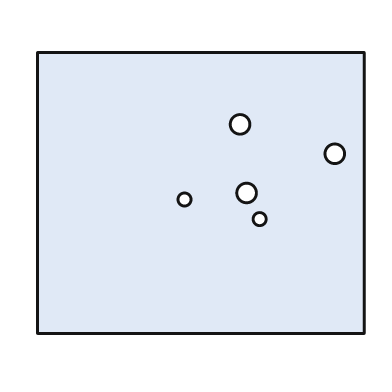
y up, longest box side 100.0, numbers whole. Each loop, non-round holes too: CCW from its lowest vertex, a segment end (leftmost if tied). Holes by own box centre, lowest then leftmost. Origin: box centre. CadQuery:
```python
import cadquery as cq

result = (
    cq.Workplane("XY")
    .moveTo(-50.0, -43.0)
    .lineTo(50.0, -43.0)
    .lineTo(50.0, 43.0)
    .lineTo(-50.0, 43.0)
    .close()
    .moveTo(18.0, -8.0)
    .circle(2.0)
    .moveTo(-5.0, -2.0)
    .circle(2.0)
    .moveTo(14.0, 0.0)
    .circle(3.0)
    .moveTo(41.0, 12.0)
    .circle(3.0)
    .moveTo(12.0, 21.0)
    .circle(3.0)
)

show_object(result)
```